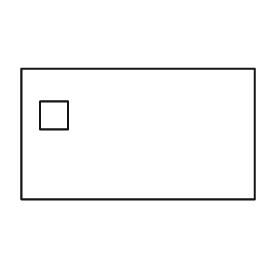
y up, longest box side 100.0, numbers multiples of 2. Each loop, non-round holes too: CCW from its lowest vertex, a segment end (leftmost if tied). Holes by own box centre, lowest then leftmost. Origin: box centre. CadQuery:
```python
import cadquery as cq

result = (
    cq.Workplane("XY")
    .moveTo(-50.0, -28.0)
    .lineTo(50.0, -28.0)
    .lineTo(50.0, 28.0)
    .lineTo(-50.0, 28.0)
    .close()
    .moveTo(-42.0, 2.0)
    .lineTo(-30.0, 2.0)
    .lineTo(-30.0, 14.0)
    .lineTo(-42.0, 14.0)
    .close()
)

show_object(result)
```